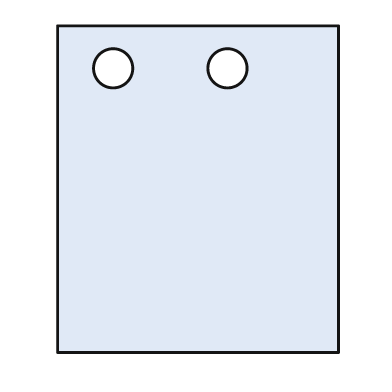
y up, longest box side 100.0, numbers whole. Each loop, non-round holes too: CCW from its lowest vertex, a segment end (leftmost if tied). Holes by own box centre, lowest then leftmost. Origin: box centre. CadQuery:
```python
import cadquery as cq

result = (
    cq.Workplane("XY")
    .moveTo(-43.0, -50.0)
    .lineTo(43.0, -50.0)
    .lineTo(43.0, 50.0)
    .lineTo(-43.0, 50.0)
    .close()
    .moveTo(-26.0, 37.0)
    .circle(6.0)
    .moveTo(9.0, 37.0)
    .circle(6.0)
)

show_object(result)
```